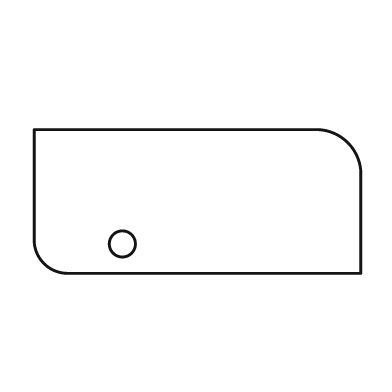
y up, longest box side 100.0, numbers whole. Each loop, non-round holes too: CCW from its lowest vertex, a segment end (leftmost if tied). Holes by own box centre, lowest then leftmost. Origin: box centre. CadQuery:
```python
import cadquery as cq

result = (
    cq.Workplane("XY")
    .moveTo(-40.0, -22.0)
    .lineTo(50.0, -22.0)
    .lineTo(50.0, 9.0)
    .threePointArc((46.0, 18.0), (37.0, 22.0))
    .lineTo(-50.0, 22.0)
    .lineTo(-50.0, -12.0)
    .threePointArc((-47.0, -19.0), (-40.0, -22.0))
    .close()
    .moveTo(-23.0, -13.0)
    .circle(4.0)
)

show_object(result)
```